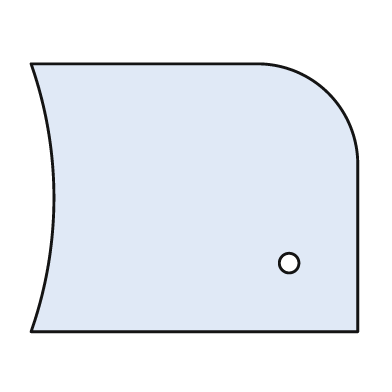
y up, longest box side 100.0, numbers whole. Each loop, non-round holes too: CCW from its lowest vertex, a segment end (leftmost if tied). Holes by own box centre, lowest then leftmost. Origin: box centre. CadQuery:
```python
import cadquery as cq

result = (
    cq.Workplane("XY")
    .moveTo(-50.0, -41.0)
    .lineTo(50.0, -41.0)
    .lineTo(50.0, 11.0)
    .threePointArc((41.0, 32.0), (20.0, 41.0))
    .lineTo(-50.0, 41.0)
    .threePointArc((-43.0, 0.0), (-50.0, -41.0))
    .close()
    .moveTo(29.0, -20.0)
    .circle(3.0)
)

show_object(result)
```